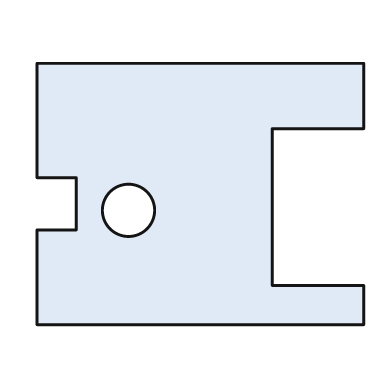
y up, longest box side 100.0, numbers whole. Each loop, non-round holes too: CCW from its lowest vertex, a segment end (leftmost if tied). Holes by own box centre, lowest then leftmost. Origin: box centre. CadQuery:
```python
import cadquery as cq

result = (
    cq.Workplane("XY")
    .moveTo(-50.0, -40.0)
    .lineTo(50.0, -40.0)
    .lineTo(50.0, -28.0)
    .lineTo(22.0, -28.0)
    .lineTo(22.0, 20.0)
    .lineTo(50.0, 20.0)
    .lineTo(50.0, 40.0)
    .lineTo(-50.0, 40.0)
    .lineTo(-50.0, 5.0)
    .lineTo(-38.0, 5.0)
    .lineTo(-38.0, -11.0)
    .lineTo(-50.0, -11.0)
    .close()
    .moveTo(-22.0, -5.0)
    .circle(8.0)
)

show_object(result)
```